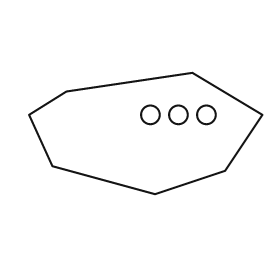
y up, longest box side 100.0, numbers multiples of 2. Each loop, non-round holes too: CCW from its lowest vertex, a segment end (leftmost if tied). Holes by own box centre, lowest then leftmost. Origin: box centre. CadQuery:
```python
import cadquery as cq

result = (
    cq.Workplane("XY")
    .moveTo(4.0, -26.0)
    .lineTo(34.0, -16.0)
    .lineTo(50.0, 8.0)
    .lineTo(20.0, 26.0)
    .lineTo(-34.0, 18.0)
    .lineTo(-50.0, 8.0)
    .lineTo(-40.0, -14.0)
    .close()
    .moveTo(2.0, 8.0)
    .circle(4.0)
    .moveTo(14.0, 8.0)
    .circle(4.0)
    .moveTo(26.0, 8.0)
    .circle(4.0)
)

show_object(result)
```